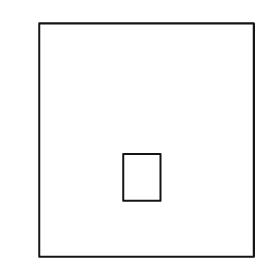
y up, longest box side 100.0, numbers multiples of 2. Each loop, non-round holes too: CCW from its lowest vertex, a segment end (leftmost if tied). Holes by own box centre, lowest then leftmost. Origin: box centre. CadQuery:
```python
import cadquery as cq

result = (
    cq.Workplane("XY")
    .moveTo(-46.0, -50.0)
    .lineTo(46.0, -50.0)
    .lineTo(46.0, 50.0)
    .lineTo(-46.0, 50.0)
    .close()
    .moveTo(-10.0, -26.0)
    .lineTo(6.0, -26.0)
    .lineTo(6.0, -6.0)
    .lineTo(-10.0, -6.0)
    .close()
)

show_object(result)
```